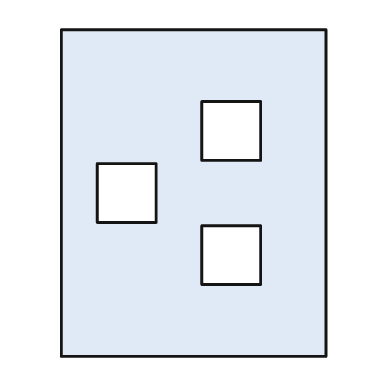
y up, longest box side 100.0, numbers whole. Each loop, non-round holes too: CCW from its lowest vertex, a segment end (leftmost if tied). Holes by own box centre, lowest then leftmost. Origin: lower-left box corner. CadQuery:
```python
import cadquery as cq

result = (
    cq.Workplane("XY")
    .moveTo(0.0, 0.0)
    .lineTo(81.0, 0.0)
    .lineTo(81.0, 100.0)
    .lineTo(0.0, 100.0)
    .close()
    .moveTo(43.0, 22.0)
    .lineTo(61.0, 22.0)
    .lineTo(61.0, 40.0)
    .lineTo(43.0, 40.0)
    .close()
    .moveTo(11.0, 41.0)
    .lineTo(29.0, 41.0)
    .lineTo(29.0, 59.0)
    .lineTo(11.0, 59.0)
    .close()
    .moveTo(43.0, 60.0)
    .lineTo(61.0, 60.0)
    .lineTo(61.0, 78.0)
    .lineTo(43.0, 78.0)
    .close()
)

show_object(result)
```